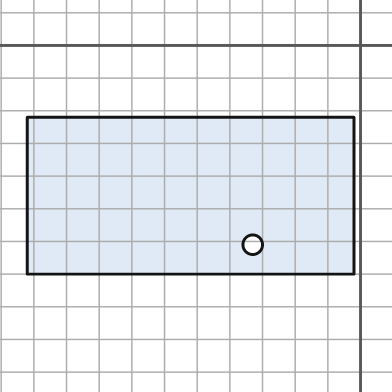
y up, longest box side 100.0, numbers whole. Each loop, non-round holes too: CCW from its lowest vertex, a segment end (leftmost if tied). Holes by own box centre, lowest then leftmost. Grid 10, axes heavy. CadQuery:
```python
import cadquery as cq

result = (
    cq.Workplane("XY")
    .moveTo(-102.0, -70.0)
    .lineTo(-2.0, -70.0)
    .lineTo(-2.0, -22.0)
    .lineTo(-102.0, -22.0)
    .close()
    .moveTo(-33.0, -61.0)
    .circle(3.0)
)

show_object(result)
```